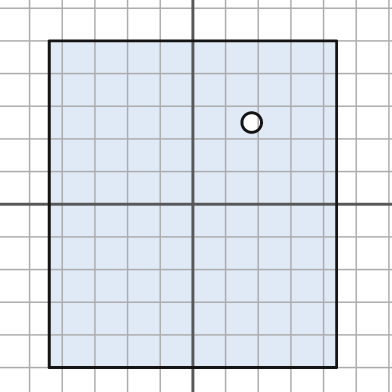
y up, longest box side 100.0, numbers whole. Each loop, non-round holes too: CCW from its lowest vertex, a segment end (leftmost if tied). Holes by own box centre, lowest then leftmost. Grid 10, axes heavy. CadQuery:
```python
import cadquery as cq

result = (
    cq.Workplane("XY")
    .moveTo(-44.0, -50.0)
    .lineTo(44.0, -50.0)
    .lineTo(44.0, 50.0)
    .lineTo(-44.0, 50.0)
    .close()
    .moveTo(18.0, 25.0)
    .circle(3.0)
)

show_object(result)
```